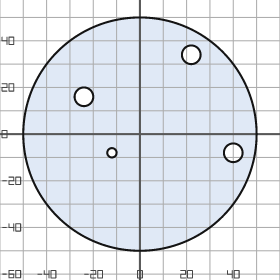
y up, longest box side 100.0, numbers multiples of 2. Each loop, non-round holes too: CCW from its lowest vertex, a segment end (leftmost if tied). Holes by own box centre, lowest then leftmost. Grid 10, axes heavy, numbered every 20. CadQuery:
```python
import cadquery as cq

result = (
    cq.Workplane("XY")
    .moveTo(0.0, 0.0)
    .circle(50.0)
    .moveTo(-12.0, -8.0)
    .circle(2.0)
    .moveTo(40.0, -8.0)
    .circle(4.0)
    .moveTo(-24.0, 16.0)
    .circle(4.0)
    .moveTo(22.0, 34.0)
    .circle(4.0)
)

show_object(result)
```